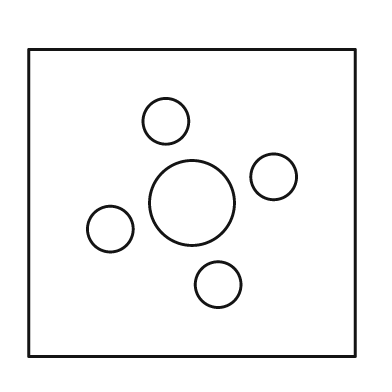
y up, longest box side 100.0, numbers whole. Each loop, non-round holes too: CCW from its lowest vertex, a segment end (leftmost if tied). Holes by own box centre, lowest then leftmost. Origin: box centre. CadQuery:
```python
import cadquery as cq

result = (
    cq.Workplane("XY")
    .moveTo(-50.0, -47.0)
    .lineTo(50.0, -47.0)
    .lineTo(50.0, 47.0)
    .lineTo(-50.0, 47.0)
    .close()
    .moveTo(8.0, -25.0)
    .circle(7.0)
    .moveTo(-25.0, -8.0)
    .circle(7.0)
    .moveTo(0.0, 0.0)
    .circle(13.0)
    .moveTo(25.0, 8.0)
    .circle(7.0)
    .moveTo(-8.0, 25.0)
    .circle(7.0)
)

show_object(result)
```